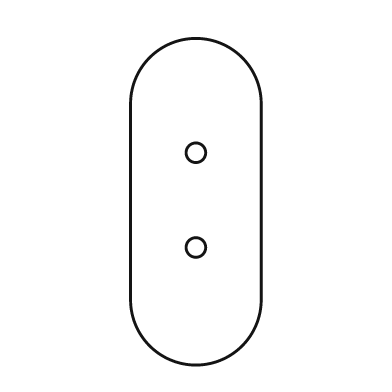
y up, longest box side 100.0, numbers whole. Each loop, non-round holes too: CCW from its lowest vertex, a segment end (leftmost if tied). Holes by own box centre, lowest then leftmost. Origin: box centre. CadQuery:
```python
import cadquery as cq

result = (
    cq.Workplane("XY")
    .moveTo(-20.0, -30.0)
    .threePointArc((0.0, -50.0), (20.0, -30.0))
    .lineTo(20.0, 30.0)
    .threePointArc((0.0, 50.0), (-20.0, 30.0))
    .close()
    .moveTo(0.0, -14.0)
    .circle(3.0)
    .moveTo(0.0, 15.0)
    .circle(3.0)
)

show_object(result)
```